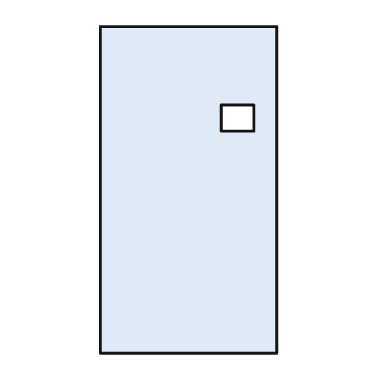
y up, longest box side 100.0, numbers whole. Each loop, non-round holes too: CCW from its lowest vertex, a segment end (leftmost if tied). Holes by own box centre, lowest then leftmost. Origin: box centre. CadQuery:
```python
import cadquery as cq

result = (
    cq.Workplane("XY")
    .moveTo(-27.0, -50.0)
    .lineTo(27.0, -50.0)
    .lineTo(27.0, 50.0)
    .lineTo(-27.0, 50.0)
    .close()
    .moveTo(10.0, 18.0)
    .lineTo(20.0, 18.0)
    .lineTo(20.0, 26.0)
    .lineTo(10.0, 26.0)
    .close()
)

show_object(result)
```